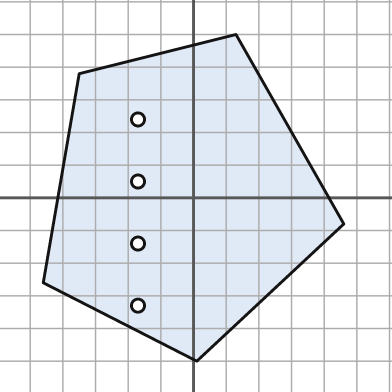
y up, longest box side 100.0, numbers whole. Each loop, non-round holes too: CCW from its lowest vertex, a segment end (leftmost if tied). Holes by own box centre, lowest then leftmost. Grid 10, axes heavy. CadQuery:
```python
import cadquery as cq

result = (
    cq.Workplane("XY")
    .moveTo(1.0, -50.0)
    .lineTo(46.0, -8.0)
    .lineTo(13.0, 50.0)
    .lineTo(-35.0, 38.0)
    .lineTo(-46.0, -26.0)
    .close()
    .moveTo(-17.0, -33.0)
    .circle(2.0)
    .moveTo(-17.0, -14.0)
    .circle(2.0)
    .moveTo(-17.0, 5.0)
    .circle(2.0)
    .moveTo(-17.0, 24.0)
    .circle(2.0)
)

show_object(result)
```